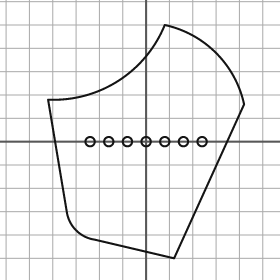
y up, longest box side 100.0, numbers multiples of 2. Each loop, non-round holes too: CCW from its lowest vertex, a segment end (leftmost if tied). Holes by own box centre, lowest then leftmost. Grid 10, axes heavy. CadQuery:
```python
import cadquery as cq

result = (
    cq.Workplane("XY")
    .moveTo(12.0, -50.0)
    .lineTo(42.0, 16.0)
    .threePointArc((30.0, 38.0), (8.0, 50.0))
    .threePointArc((-12.0, 26.0), (-42.0, 18.0))
    .lineTo(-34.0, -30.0)
    .threePointArc((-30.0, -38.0), (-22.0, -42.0))
    .close()
    .moveTo(-24.0, 0.0)
    .circle(2.0)
    .moveTo(-16.0, 0.0)
    .circle(2.0)
    .moveTo(-8.0, 0.0)
    .circle(2.0)
    .moveTo(0.0, 0.0)
    .circle(2.0)
    .moveTo(8.0, 0.0)
    .circle(2.0)
    .moveTo(16.0, 0.0)
    .circle(2.0)
    .moveTo(24.0, 0.0)
    .circle(2.0)
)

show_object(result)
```